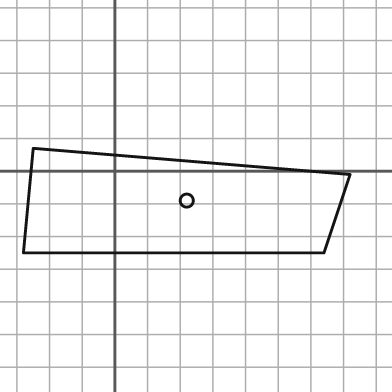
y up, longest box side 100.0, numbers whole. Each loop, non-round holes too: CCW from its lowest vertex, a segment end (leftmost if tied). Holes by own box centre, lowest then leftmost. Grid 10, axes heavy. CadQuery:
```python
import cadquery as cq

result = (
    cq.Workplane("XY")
    .moveTo(-28.0, -25.0)
    .lineTo(64.0, -25.0)
    .lineTo(72.0, -1.0)
    .lineTo(-25.0, 7.0)
    .close()
    .moveTo(22.0, -9.0)
    .circle(2.0)
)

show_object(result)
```